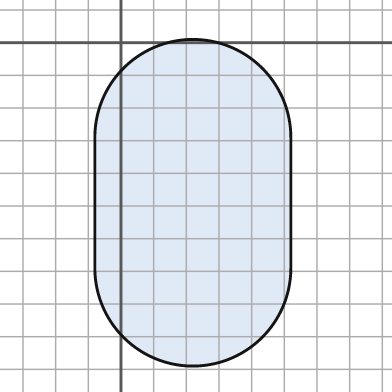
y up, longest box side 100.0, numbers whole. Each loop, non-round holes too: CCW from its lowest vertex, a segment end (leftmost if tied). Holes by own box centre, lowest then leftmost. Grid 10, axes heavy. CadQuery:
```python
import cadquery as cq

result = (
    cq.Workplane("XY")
    .moveTo(-8.0, -69.0)
    .threePointArc((22.0, -99.0), (52.0, -69.0))
    .lineTo(52.0, -29.0)
    .threePointArc((22.0, 1.0), (-8.0, -29.0))
    .close()
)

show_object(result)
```